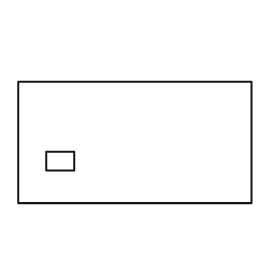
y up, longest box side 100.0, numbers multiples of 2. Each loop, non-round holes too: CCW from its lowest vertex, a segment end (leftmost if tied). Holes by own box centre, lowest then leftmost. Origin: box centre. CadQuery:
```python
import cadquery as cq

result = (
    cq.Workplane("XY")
    .moveTo(-50.0, -26.0)
    .lineTo(50.0, -26.0)
    .lineTo(50.0, 26.0)
    .lineTo(-50.0, 26.0)
    .close()
    .moveTo(-38.0, -12.0)
    .lineTo(-26.0, -12.0)
    .lineTo(-26.0, -4.0)
    .lineTo(-38.0, -4.0)
    .close()
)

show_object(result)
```